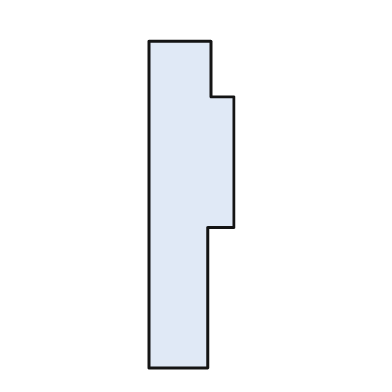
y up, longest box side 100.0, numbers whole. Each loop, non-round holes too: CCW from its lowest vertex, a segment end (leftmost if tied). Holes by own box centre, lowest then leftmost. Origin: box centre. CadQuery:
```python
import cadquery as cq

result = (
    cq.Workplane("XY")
    .moveTo(-13.0, -50.0)
    .lineTo(5.0, -50.0)
    .lineTo(5.0, -7.0)
    .lineTo(13.0, -7.0)
    .lineTo(13.0, 33.0)
    .lineTo(6.0, 33.0)
    .lineTo(6.0, 50.0)
    .lineTo(-13.0, 50.0)
    .close()
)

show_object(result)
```